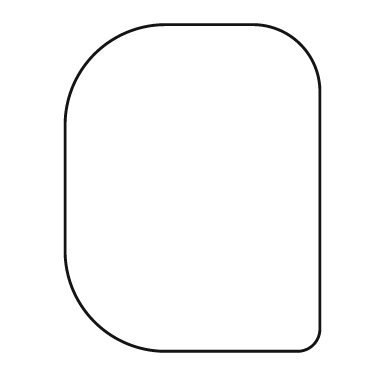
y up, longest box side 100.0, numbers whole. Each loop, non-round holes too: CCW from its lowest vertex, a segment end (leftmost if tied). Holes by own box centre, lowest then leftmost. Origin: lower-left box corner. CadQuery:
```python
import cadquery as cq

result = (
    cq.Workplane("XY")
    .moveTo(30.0, 0.0)
    .lineTo(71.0, 0.0)
    .threePointArc((76.0, 2.0), (78.0, 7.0))
    .lineTo(78.0, 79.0)
    .threePointArc((72.0, 94.0), (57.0, 100.0))
    .lineTo(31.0, 100.0)
    .threePointArc((9.0, 91.0), (0.0, 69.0))
    .lineTo(0.0, 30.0)
    .threePointArc((9.0, 9.0), (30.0, 0.0))
    .close()
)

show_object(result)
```